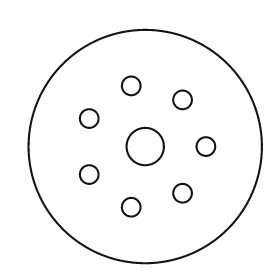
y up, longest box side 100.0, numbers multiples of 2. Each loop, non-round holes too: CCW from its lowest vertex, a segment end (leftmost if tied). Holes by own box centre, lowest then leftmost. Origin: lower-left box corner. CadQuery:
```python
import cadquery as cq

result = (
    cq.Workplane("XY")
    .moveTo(50.0, 50.0)
    .circle(50.0)
    .moveTo(44.0, 24.0)
    .circle(4.0)
    .moveTo(66.0, 30.0)
    .circle(4.0)
    .moveTo(26.0, 38.0)
    .circle(4.0)
    .moveTo(50.0, 50.0)
    .circle(8.0)
    .moveTo(76.0, 50.0)
    .circle(4.0)
    .moveTo(26.0, 62.0)
    .circle(4.0)
    .moveTo(66.0, 70.0)
    .circle(4.0)
    .moveTo(44.0, 76.0)
    .circle(4.0)
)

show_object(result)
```